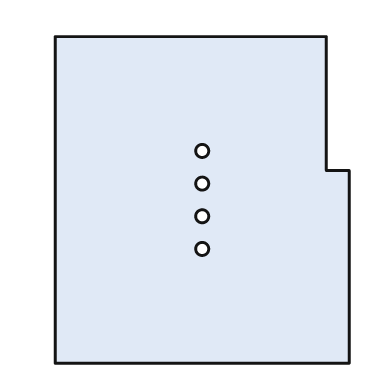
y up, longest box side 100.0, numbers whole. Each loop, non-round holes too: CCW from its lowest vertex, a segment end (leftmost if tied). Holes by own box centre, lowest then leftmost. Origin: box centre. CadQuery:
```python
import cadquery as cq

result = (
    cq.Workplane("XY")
    .moveTo(-45.0, -50.0)
    .lineTo(45.0, -50.0)
    .lineTo(45.0, 9.0)
    .lineTo(38.0, 9.0)
    .lineTo(38.0, 50.0)
    .lineTo(-45.0, 50.0)
    .close()
    .moveTo(0.0, -15.0)
    .circle(2.0)
    .moveTo(0.0, -5.0)
    .circle(2.0)
    .moveTo(0.0, 5.0)
    .circle(2.0)
    .moveTo(0.0, 15.0)
    .circle(2.0)
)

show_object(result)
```